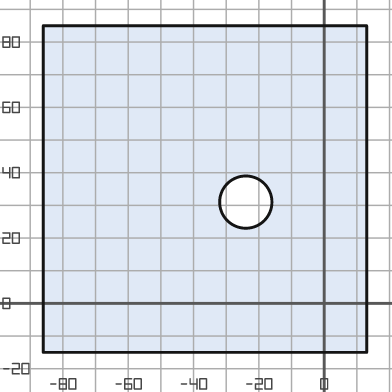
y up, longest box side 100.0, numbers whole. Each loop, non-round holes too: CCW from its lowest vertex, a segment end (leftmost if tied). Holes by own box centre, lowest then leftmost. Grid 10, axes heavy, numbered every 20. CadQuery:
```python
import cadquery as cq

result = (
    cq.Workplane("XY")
    .moveTo(-86.0, -15.0)
    .lineTo(13.0, -15.0)
    .lineTo(13.0, 85.0)
    .lineTo(-86.0, 85.0)
    .close()
    .moveTo(-24.0, 31.0)
    .circle(8.0)
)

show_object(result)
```